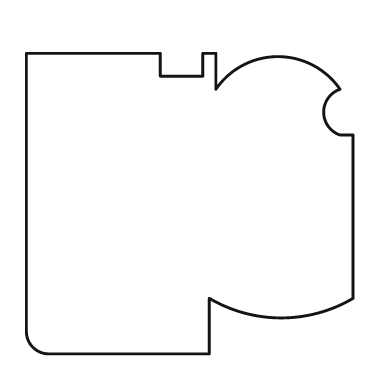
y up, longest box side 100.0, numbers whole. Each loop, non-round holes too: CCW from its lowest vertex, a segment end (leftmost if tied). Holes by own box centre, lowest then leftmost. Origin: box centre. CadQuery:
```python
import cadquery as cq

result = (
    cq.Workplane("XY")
    .moveTo(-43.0, -46.0)
    .lineTo(6.0, -46.0)
    .lineTo(6.0, -29.0)
    .threePointArc((28.0, -35.0), (50.0, -29.0))
    .lineTo(50.0, 21.0)
    .lineTo(46.0, 21.0)
    .threePointArc((41.0, 28.0), (46.0, 35.0))
    .threePointArc((27.0, 45.0), (8.0, 35.0))
    .lineTo(8.0, 46.0)
    .lineTo(4.0, 46.0)
    .lineTo(4.0, 39.0)
    .lineTo(-9.0, 39.0)
    .lineTo(-9.0, 46.0)
    .lineTo(-50.0, 46.0)
    .lineTo(-50.0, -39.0)
    .threePointArc((-48.0, -44.0), (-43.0, -46.0))
    .close()
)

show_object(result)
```